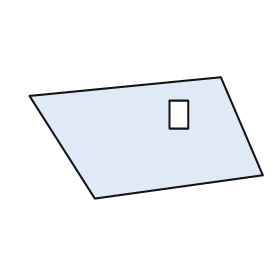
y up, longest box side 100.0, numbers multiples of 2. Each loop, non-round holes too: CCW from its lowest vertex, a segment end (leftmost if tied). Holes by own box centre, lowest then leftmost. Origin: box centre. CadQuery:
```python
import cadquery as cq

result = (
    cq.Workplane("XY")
    .moveTo(-22.0, -26.0)
    .lineTo(50.0, -16.0)
    .lineTo(32.0, 26.0)
    .lineTo(-50.0, 18.0)
    .close()
    .moveTo(10.0, 4.0)
    .lineTo(18.0, 4.0)
    .lineTo(18.0, 16.0)
    .lineTo(10.0, 16.0)
    .close()
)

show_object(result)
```